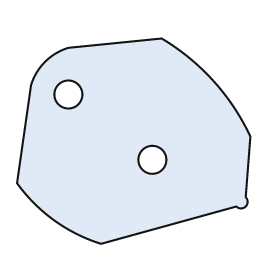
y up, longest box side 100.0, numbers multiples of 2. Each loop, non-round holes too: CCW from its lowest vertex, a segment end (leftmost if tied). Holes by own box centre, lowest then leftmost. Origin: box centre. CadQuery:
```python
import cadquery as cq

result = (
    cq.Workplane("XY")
    .moveTo(-14.0, -44.0)
    .lineTo(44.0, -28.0)
    .threePointArc((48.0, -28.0), (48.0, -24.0))
    .lineTo(50.0, 2.0)
    .threePointArc((34.0, 26.0), (12.0, 44.0))
    .lineTo(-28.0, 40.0)
    .threePointArc((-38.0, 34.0), (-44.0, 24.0))
    .lineTo(-50.0, -18.0)
    .threePointArc((-34.0, -34.0), (-14.0, -44.0))
    .close()
    .moveTo(8.0, -8.0)
    .circle(6.0)
    .moveTo(-28.0, 20.0)
    .circle(6.0)
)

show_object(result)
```